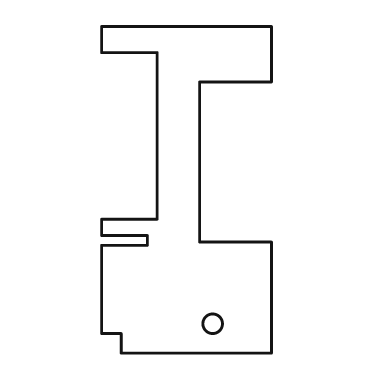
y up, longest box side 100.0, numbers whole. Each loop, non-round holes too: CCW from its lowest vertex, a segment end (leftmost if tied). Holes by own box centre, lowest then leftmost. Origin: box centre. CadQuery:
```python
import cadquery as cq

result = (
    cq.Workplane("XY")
    .moveTo(-20.0, -50.0)
    .lineTo(26.0, -50.0)
    .lineTo(26.0, -16.0)
    .lineTo(4.0, -16.0)
    .lineTo(4.0, 33.0)
    .lineTo(26.0, 33.0)
    .lineTo(26.0, 50.0)
    .lineTo(-26.0, 50.0)
    .lineTo(-26.0, 42.0)
    .lineTo(-9.0, 42.0)
    .lineTo(-9.0, -9.0)
    .lineTo(-26.0, -9.0)
    .lineTo(-26.0, -14.0)
    .lineTo(-12.0, -14.0)
    .lineTo(-12.0, -17.0)
    .lineTo(-26.0, -17.0)
    .lineTo(-26.0, -44.0)
    .lineTo(-20.0, -44.0)
    .close()
    .moveTo(8.0, -41.0)
    .circle(3.0)
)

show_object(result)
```